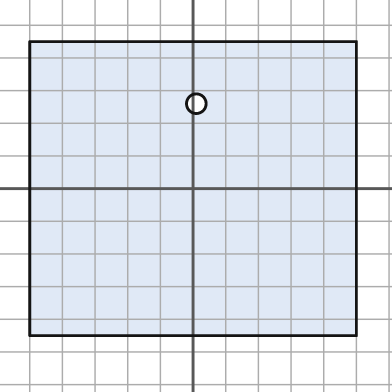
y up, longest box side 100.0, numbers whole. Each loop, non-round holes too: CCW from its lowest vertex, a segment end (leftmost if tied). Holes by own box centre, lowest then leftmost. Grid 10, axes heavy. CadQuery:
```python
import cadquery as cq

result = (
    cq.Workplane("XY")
    .moveTo(-50.0, -45.0)
    .lineTo(50.0, -45.0)
    .lineTo(50.0, 45.0)
    .lineTo(-50.0, 45.0)
    .close()
    .moveTo(1.0, 26.0)
    .circle(3.0)
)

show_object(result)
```